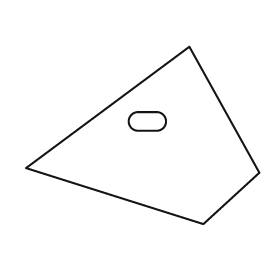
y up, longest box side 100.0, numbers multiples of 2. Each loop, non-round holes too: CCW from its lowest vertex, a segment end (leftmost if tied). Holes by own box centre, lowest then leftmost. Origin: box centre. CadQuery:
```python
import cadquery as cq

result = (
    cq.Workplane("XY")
    .moveTo(26.0, -38.0)
    .lineTo(50.0, -16.0)
    .lineTo(20.0, 38.0)
    .lineTo(-50.0, -14.0)
    .close()
    .moveTo(-2.0, 2.0)
    .lineTo(6.0, 2.0)
    .threePointArc((10.0, 6.0), (6.0, 10.0))
    .lineTo(-2.0, 10.0)
    .threePointArc((-6.0, 6.0), (-2.0, 2.0))
    .close()
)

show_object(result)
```